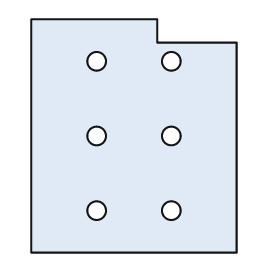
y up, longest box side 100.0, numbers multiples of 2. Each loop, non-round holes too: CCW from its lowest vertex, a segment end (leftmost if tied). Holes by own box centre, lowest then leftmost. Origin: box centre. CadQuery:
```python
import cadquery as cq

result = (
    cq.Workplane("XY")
    .moveTo(-44.0, -50.0)
    .lineTo(44.0, -50.0)
    .lineTo(44.0, 40.0)
    .lineTo(10.0, 40.0)
    .lineTo(10.0, 50.0)
    .lineTo(-44.0, 50.0)
    .close()
    .moveTo(-16.0, -32.0)
    .circle(4.0)
    .moveTo(16.0, -32.0)
    .circle(4.0)
    .moveTo(-16.0, 0.0)
    .circle(4.0)
    .moveTo(16.0, 0.0)
    .circle(4.0)
    .moveTo(-16.0, 32.0)
    .circle(4.0)
    .moveTo(16.0, 32.0)
    .circle(4.0)
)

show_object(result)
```